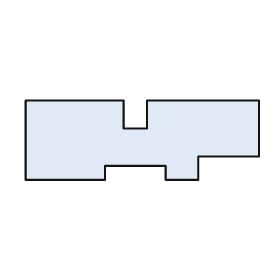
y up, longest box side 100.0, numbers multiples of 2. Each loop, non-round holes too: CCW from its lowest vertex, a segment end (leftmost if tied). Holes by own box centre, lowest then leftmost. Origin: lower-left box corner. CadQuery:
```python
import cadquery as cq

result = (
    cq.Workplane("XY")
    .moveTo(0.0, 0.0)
    .lineTo(34.0, 0.0)
    .lineTo(34.0, 6.0)
    .lineTo(60.0, 6.0)
    .lineTo(60.0, 0.0)
    .lineTo(74.0, 0.0)
    .lineTo(74.0, 10.0)
    .lineTo(100.0, 10.0)
    .lineTo(100.0, 34.0)
    .lineTo(52.0, 34.0)
    .lineTo(52.0, 22.0)
    .lineTo(42.0, 22.0)
    .lineTo(42.0, 34.0)
    .lineTo(0.0, 34.0)
    .close()
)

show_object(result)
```